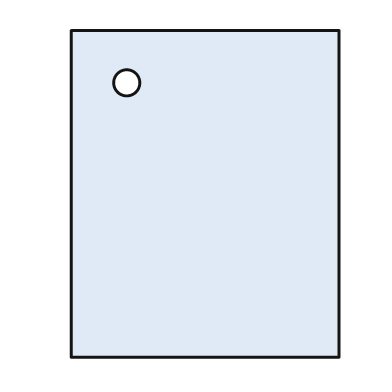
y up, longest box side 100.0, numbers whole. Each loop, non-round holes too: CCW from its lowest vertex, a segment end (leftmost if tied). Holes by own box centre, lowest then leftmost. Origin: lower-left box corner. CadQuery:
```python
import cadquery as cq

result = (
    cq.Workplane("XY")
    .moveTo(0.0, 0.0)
    .lineTo(82.0, 0.0)
    .lineTo(82.0, 100.0)
    .lineTo(0.0, 100.0)
    .close()
    .moveTo(17.0, 84.0)
    .circle(4.0)
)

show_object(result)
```